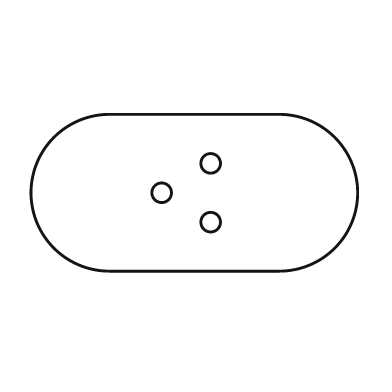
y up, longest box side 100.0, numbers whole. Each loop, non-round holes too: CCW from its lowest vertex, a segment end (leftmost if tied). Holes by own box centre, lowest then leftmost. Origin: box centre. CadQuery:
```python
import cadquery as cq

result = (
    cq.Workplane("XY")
    .moveTo(-26.0, -24.0)
    .lineTo(26.0, -24.0)
    .threePointArc((50.0, 0.0), (26.0, 24.0))
    .lineTo(-26.0, 24.0)
    .threePointArc((-50.0, 0.0), (-26.0, -24.0))
    .close()
    .moveTo(5.0, -9.0)
    .circle(3.0)
    .moveTo(-10.0, 0.0)
    .circle(3.0)
    .moveTo(5.0, 9.0)
    .circle(3.0)
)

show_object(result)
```